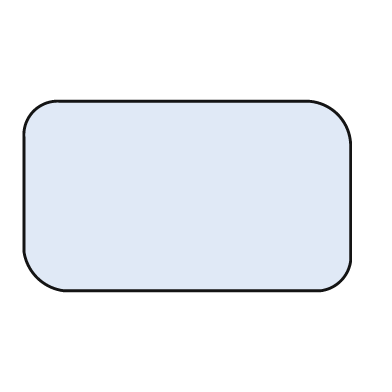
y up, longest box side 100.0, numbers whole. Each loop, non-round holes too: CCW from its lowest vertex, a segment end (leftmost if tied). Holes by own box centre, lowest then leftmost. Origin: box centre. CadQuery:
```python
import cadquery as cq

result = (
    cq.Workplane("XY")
    .moveTo(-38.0, -29.0)
    .lineTo(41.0, -29.0)
    .threePointArc((47.0, -26.0), (50.0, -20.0))
    .lineTo(50.0, 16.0)
    .threePointArc((46.0, 25.0), (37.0, 29.0))
    .lineTo(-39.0, 29.0)
    .threePointArc((-47.0, 26.0), (-50.0, 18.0))
    .lineTo(-50.0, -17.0)
    .threePointArc((-46.0, -25.0), (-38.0, -29.0))
    .close()
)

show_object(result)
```